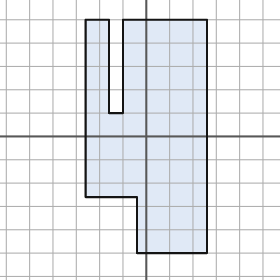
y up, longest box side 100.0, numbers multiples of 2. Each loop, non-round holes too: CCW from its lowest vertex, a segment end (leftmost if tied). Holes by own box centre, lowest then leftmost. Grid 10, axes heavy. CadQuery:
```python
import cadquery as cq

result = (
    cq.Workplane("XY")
    .moveTo(-4.0, -50.0)
    .lineTo(26.0, -50.0)
    .lineTo(26.0, 50.0)
    .lineTo(-10.0, 50.0)
    .lineTo(-10.0, 10.0)
    .lineTo(-16.0, 10.0)
    .lineTo(-16.0, 50.0)
    .lineTo(-26.0, 50.0)
    .lineTo(-26.0, -26.0)
    .lineTo(-4.0, -26.0)
    .close()
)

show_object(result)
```